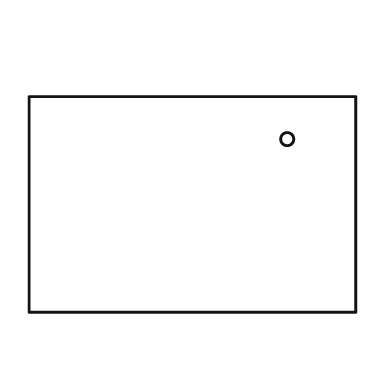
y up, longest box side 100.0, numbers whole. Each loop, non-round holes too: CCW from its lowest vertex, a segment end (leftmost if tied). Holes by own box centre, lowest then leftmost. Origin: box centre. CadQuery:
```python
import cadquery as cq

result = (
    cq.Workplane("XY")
    .moveTo(-50.0, -33.0)
    .lineTo(50.0, -33.0)
    .lineTo(50.0, 33.0)
    .lineTo(-50.0, 33.0)
    .close()
    .moveTo(29.0, 20.0)
    .circle(2.0)
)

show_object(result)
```